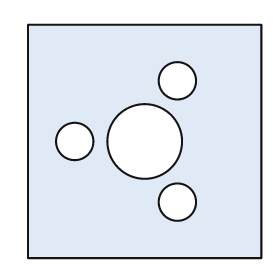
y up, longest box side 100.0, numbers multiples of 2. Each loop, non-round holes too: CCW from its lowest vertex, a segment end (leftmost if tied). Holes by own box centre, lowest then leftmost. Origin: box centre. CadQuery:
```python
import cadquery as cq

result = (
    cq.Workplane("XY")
    .moveTo(-50.0, -50.0)
    .lineTo(50.0, -50.0)
    .lineTo(50.0, 50.0)
    .lineTo(-50.0, 50.0)
    .close()
    .moveTo(14.0, -26.0)
    .circle(8.0)
    .moveTo(-30.0, 0.0)
    .circle(8.0)
    .moveTo(0.0, 0.0)
    .circle(16.0)
    .moveTo(14.0, 26.0)
    .circle(8.0)
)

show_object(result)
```